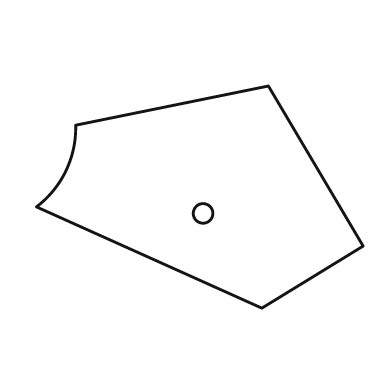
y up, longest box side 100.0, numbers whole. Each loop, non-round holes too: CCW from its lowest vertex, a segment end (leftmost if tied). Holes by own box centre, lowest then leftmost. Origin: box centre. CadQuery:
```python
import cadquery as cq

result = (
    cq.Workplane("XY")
    .moveTo(19.0, -34.0)
    .lineTo(50.0, -15.0)
    .lineTo(21.0, 34.0)
    .lineTo(-38.0, 22.0)
    .threePointArc((-41.0, 8.0), (-50.0, -3.0))
    .close()
    .moveTo(1.0, -5.0)
    .circle(3.0)
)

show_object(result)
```